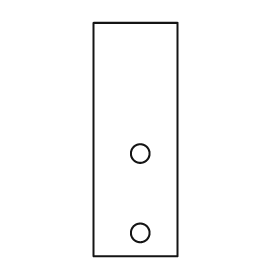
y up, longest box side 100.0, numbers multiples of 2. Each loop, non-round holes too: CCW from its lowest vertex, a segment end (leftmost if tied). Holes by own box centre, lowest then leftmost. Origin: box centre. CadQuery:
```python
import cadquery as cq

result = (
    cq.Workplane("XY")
    .moveTo(-18.0, -50.0)
    .lineTo(18.0, -50.0)
    .lineTo(18.0, 50.0)
    .lineTo(-18.0, 50.0)
    .close()
    .moveTo(2.0, -40.0)
    .circle(4.0)
    .moveTo(2.0, -6.0)
    .circle(4.0)
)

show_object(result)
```